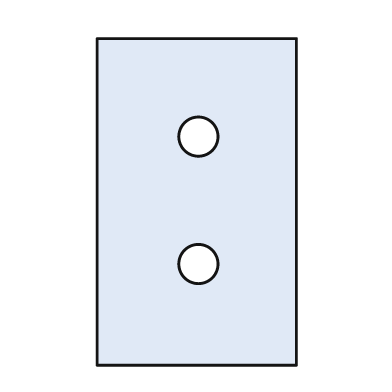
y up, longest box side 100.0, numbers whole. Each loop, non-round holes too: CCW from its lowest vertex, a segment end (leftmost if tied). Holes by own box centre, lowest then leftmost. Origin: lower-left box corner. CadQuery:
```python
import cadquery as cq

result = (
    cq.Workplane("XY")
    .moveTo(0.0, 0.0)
    .lineTo(61.0, 0.0)
    .lineTo(61.0, 100.0)
    .lineTo(0.0, 100.0)
    .close()
    .moveTo(31.0, 31.0)
    .circle(6.0)
    .moveTo(31.0, 70.0)
    .circle(6.0)
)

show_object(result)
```